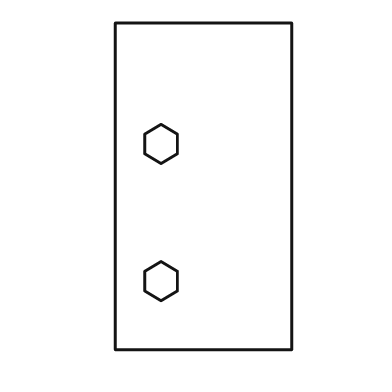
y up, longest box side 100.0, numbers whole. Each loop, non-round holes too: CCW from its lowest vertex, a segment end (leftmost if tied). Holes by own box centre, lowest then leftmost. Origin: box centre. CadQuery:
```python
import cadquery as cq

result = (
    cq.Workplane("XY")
    .moveTo(-27.0, -50.0)
    .lineTo(27.0, -50.0)
    .lineTo(27.0, 50.0)
    .lineTo(-27.0, 50.0)
    .close()
    .moveTo(-13.0, -35.0)
    .lineTo(-8.0, -32.0)
    .lineTo(-8.0, -26.0)
    .lineTo(-13.0, -23.0)
    .lineTo(-18.0, -26.0)
    .lineTo(-18.0, -32.0)
    .close()
    .moveTo(-13.0, 7.0)
    .lineTo(-8.0, 10.0)
    .lineTo(-8.0, 16.0)
    .lineTo(-13.0, 19.0)
    .lineTo(-18.0, 16.0)
    .lineTo(-18.0, 10.0)
    .close()
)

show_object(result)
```